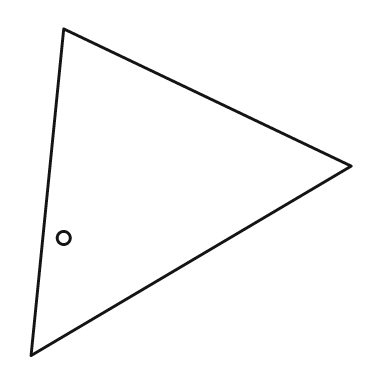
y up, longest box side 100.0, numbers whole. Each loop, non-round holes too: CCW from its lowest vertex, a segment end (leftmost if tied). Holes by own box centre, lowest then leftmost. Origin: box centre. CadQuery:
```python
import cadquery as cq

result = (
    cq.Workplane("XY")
    .moveTo(-49.0, -50.0)
    .lineTo(49.0, 8.0)
    .lineTo(-39.0, 50.0)
    .close()
    .moveTo(-39.0, -14.0)
    .circle(2.0)
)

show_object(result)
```